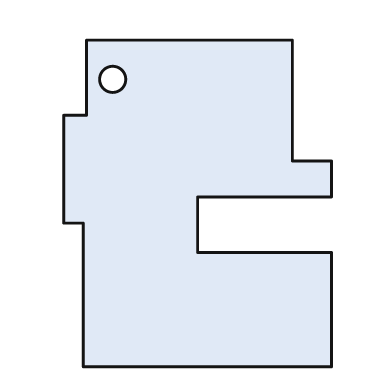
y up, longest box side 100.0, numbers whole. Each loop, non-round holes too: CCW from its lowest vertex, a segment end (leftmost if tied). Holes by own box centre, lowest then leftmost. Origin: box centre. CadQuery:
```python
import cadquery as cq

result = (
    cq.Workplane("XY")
    .moveTo(-35.0, -50.0)
    .lineTo(41.0, -50.0)
    .lineTo(41.0, -15.0)
    .lineTo(0.0, -15.0)
    .lineTo(0.0, 2.0)
    .lineTo(41.0, 2.0)
    .lineTo(41.0, 13.0)
    .lineTo(29.0, 13.0)
    .lineTo(29.0, 50.0)
    .lineTo(-34.0, 50.0)
    .lineTo(-34.0, 27.0)
    .lineTo(-41.0, 27.0)
    .lineTo(-41.0, -6.0)
    .lineTo(-35.0, -6.0)
    .close()
    .moveTo(-26.0, 38.0)
    .circle(4.0)
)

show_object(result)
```